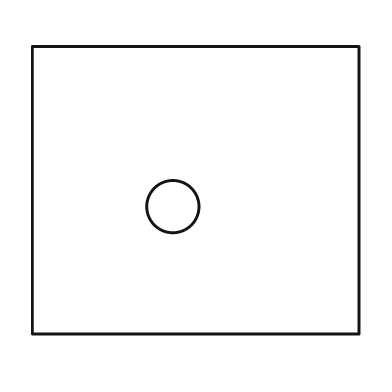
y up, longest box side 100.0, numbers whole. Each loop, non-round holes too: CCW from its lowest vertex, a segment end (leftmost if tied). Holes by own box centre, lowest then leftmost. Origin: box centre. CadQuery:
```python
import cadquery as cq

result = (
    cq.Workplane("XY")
    .moveTo(-50.0, -44.0)
    .lineTo(50.0, -44.0)
    .lineTo(50.0, 44.0)
    .lineTo(-50.0, 44.0)
    .close()
    .moveTo(-7.0, -5.0)
    .circle(8.0)
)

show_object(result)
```